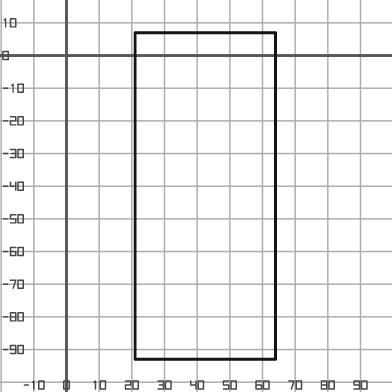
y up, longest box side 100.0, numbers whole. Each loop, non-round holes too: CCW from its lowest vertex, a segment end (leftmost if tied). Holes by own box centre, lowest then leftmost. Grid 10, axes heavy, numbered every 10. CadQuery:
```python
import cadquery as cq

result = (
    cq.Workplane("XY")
    .moveTo(21.0, -93.0)
    .lineTo(64.0, -93.0)
    .lineTo(64.0, 7.0)
    .lineTo(21.0, 7.0)
    .close()
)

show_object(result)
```